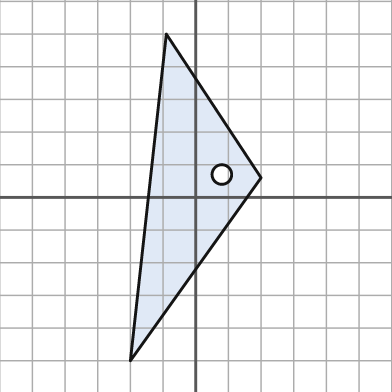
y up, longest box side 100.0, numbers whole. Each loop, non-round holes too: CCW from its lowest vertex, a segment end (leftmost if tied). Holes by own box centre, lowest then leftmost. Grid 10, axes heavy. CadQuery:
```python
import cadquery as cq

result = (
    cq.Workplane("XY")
    .moveTo(-20.0, -50.0)
    .lineTo(20.0, 6.0)
    .lineTo(-9.0, 50.0)
    .close()
    .moveTo(8.0, 7.0)
    .circle(3.0)
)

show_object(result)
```